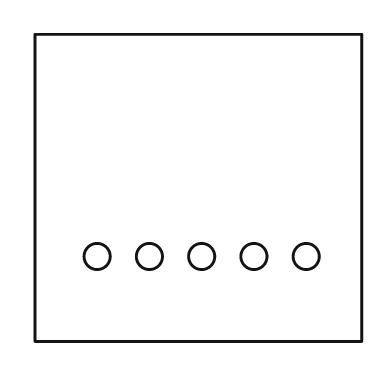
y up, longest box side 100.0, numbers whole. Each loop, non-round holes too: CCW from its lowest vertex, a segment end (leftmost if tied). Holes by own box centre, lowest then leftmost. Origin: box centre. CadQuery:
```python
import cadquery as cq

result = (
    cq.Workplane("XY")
    .moveTo(-50.0, -47.0)
    .lineTo(50.0, -47.0)
    .lineTo(50.0, 47.0)
    .lineTo(-50.0, 47.0)
    .close()
    .moveTo(-31.0, -21.0)
    .circle(4.0)
    .moveTo(-15.0, -21.0)
    .circle(4.0)
    .moveTo(1.0, -21.0)
    .circle(4.0)
    .moveTo(17.0, -21.0)
    .circle(4.0)
    .moveTo(33.0, -21.0)
    .circle(4.0)
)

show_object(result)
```